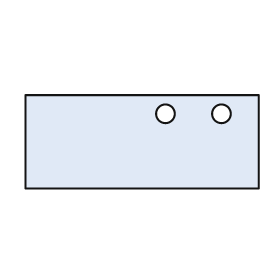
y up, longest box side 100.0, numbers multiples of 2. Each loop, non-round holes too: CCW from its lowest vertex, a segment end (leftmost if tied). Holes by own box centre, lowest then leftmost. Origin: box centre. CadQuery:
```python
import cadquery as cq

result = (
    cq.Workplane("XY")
    .moveTo(-50.0, -20.0)
    .lineTo(50.0, -20.0)
    .lineTo(50.0, 20.0)
    .lineTo(-50.0, 20.0)
    .close()
    .moveTo(10.0, 12.0)
    .circle(4.0)
    .moveTo(34.0, 12.0)
    .circle(4.0)
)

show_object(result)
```